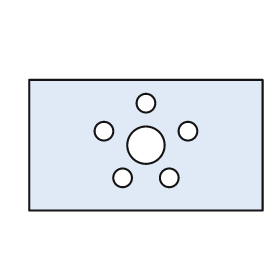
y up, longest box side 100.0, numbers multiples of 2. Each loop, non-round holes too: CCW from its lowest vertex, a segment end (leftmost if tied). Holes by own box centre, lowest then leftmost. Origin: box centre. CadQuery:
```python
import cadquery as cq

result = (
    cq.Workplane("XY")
    .moveTo(-50.0, -28.0)
    .lineTo(50.0, -28.0)
    .lineTo(50.0, 28.0)
    .lineTo(-50.0, 28.0)
    .close()
    .moveTo(-10.0, -14.0)
    .circle(4.0)
    .moveTo(10.0, -14.0)
    .circle(4.0)
    .moveTo(0.0, 0.0)
    .circle(8.0)
    .moveTo(-18.0, 6.0)
    .circle(4.0)
    .moveTo(18.0, 6.0)
    .circle(4.0)
    .moveTo(0.0, 18.0)
    .circle(4.0)
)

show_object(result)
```